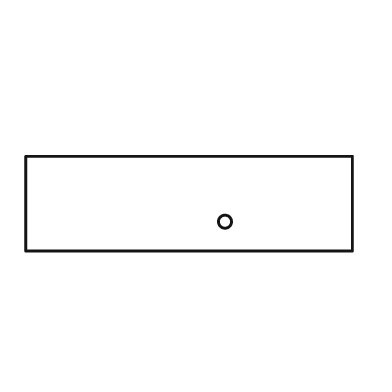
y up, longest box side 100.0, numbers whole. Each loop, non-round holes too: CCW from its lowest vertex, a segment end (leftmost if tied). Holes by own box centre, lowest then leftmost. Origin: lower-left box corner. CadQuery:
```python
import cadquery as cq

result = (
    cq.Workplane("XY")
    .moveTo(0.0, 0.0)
    .lineTo(100.0, 0.0)
    .lineTo(100.0, 29.0)
    .lineTo(0.0, 29.0)
    .close()
    .moveTo(61.0, 9.0)
    .circle(2.0)
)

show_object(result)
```